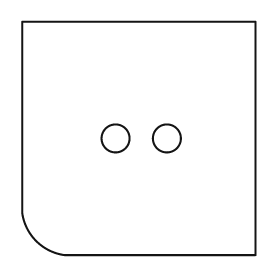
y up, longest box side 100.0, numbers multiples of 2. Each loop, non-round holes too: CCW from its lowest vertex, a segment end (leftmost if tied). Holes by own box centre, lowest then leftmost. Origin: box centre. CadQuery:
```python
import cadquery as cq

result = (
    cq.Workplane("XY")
    .moveTo(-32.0, -50.0)
    .lineTo(50.0, -50.0)
    .lineTo(50.0, 50.0)
    .lineTo(-50.0, 50.0)
    .lineTo(-50.0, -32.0)
    .threePointArc((-44.0, -44.0), (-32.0, -50.0))
    .close()
    .moveTo(-10.0, 0.0)
    .circle(6.0)
    .moveTo(12.0, 0.0)
    .circle(6.0)
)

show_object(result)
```